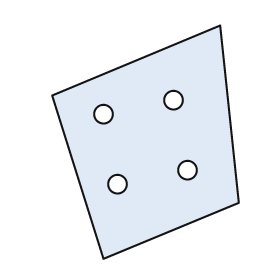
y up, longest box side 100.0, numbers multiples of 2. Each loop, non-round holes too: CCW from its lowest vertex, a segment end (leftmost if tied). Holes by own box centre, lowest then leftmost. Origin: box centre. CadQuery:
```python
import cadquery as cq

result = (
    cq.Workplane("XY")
    .moveTo(-18.0, -50.0)
    .lineTo(40.0, -26.0)
    .lineTo(32.0, 50.0)
    .lineTo(-40.0, 20.0)
    .close()
    .moveTo(-12.0, -18.0)
    .circle(4.0)
    .moveTo(18.0, -12.0)
    .circle(4.0)
    .moveTo(-18.0, 12.0)
    .circle(4.0)
    .moveTo(12.0, 18.0)
    .circle(4.0)
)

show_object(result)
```